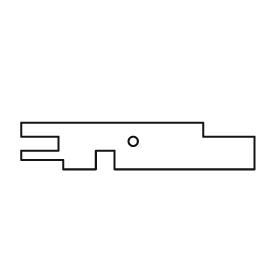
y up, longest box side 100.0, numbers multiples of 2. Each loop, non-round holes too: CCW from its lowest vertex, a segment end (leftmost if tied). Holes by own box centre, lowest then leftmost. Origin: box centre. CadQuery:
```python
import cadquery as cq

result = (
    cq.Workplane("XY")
    .moveTo(-32.0, -10.0)
    .lineTo(-18.0, -10.0)
    .lineTo(-18.0, -2.0)
    .lineTo(-10.0, -2.0)
    .lineTo(-10.0, -10.0)
    .lineTo(50.0, -10.0)
    .lineTo(50.0, 4.0)
    .lineTo(28.0, 4.0)
    .lineTo(28.0, 10.0)
    .lineTo(-50.0, 10.0)
    .lineTo(-50.0, 4.0)
    .lineTo(-34.0, 4.0)
    .lineTo(-34.0, -2.0)
    .lineTo(-50.0, -2.0)
    .lineTo(-50.0, -6.0)
    .lineTo(-32.0, -6.0)
    .close()
    .moveTo(-2.0, 2.0)
    .circle(2.0)
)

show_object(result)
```